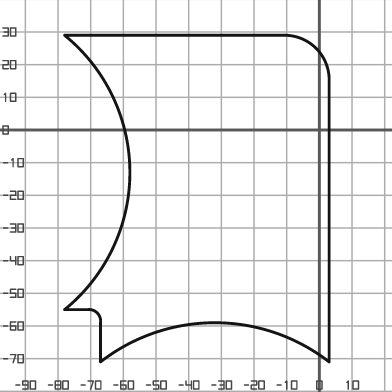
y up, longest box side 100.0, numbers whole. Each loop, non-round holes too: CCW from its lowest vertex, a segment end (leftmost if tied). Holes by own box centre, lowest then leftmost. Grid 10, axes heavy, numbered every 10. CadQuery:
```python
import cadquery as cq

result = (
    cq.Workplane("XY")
    .moveTo(-67.0, -71.0)
    .threePointArc((-32.0, -59.0), (3.0, -71.0))
    .lineTo(3.0, 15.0)
    .threePointArc((-1.0, 25.0), (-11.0, 29.0))
    .lineTo(-78.0, 29.0)
    .threePointArc((-58.0, -13.0), (-78.0, -55.0))
    .lineTo(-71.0, -55.0)
    .threePointArc((-68.0, -56.0), (-67.0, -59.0))
    .close()
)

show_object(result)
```